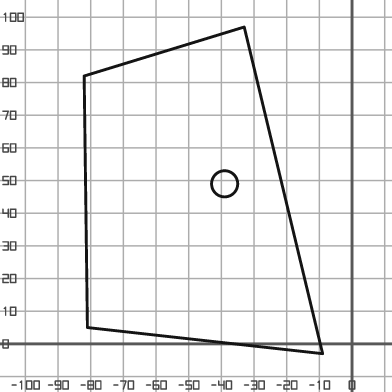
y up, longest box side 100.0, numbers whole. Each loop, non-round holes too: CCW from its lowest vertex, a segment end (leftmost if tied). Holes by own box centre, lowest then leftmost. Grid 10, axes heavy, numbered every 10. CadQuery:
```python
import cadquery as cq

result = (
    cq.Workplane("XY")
    .moveTo(-9.0, -3.0)
    .lineTo(-33.0, 97.0)
    .lineTo(-82.0, 82.0)
    .lineTo(-81.0, 5.0)
    .close()
    .moveTo(-39.0, 49.0)
    .circle(4.0)
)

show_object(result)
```